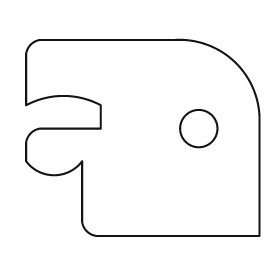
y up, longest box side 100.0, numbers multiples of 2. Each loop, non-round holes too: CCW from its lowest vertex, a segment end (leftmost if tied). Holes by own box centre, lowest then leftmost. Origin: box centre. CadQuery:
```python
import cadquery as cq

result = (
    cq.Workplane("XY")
    .moveTo(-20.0, -42.0)
    .lineTo(50.0, -42.0)
    .lineTo(50.0, 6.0)
    .threePointArc((40.0, 32.0), (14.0, 42.0))
    .lineTo(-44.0, 42.0)
    .threePointArc((-48.0, 40.0), (-50.0, 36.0))
    .lineTo(-50.0, 14.0)
    .threePointArc((-34.0, 18.0), (-18.0, 14.0))
    .lineTo(-18.0, 4.0)
    .lineTo(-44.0, 4.0)
    .threePointArc((-48.0, 2.0), (-50.0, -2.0))
    .lineTo(-50.0, -10.0)
    .threePointArc((-38.0, -16.0), (-26.0, -10.0))
    .lineTo(-26.0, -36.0)
    .threePointArc((-24.0, -40.0), (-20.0, -42.0))
    .close()
    .moveTo(24.0, 4.0)
    .circle(8.0)
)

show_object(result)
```